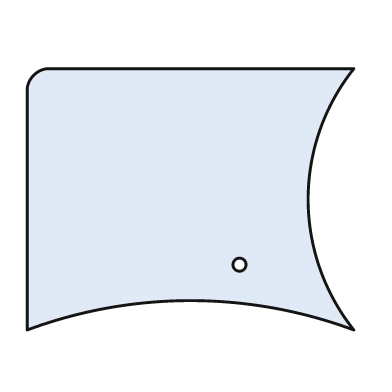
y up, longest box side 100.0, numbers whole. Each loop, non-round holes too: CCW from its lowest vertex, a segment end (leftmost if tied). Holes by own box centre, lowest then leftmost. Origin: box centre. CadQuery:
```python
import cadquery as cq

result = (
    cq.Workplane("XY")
    .moveTo(-50.0, -40.0)
    .threePointArc((0.0, -31.0), (50.0, -40.0))
    .threePointArc((36.0, 0.0), (50.0, 40.0))
    .lineTo(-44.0, 40.0)
    .threePointArc((-48.0, 38.0), (-50.0, 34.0))
    .close()
    .moveTo(15.0, -20.0)
    .circle(2.0)
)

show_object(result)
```